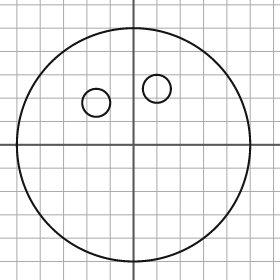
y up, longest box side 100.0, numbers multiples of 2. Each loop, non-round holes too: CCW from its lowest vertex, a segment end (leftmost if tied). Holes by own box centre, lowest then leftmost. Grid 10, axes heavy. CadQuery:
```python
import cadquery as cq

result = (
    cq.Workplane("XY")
    .moveTo(0.0, 0.0)
    .circle(50.0)
    .moveTo(-16.0, 18.0)
    .circle(6.0)
    .moveTo(10.0, 24.0)
    .circle(6.0)
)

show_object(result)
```